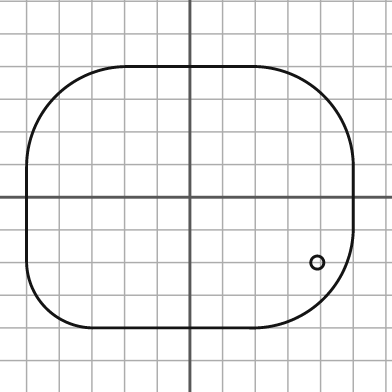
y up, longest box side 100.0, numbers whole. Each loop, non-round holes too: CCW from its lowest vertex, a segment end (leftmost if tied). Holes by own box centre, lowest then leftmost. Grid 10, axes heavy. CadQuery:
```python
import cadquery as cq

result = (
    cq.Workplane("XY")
    .moveTo(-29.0, -40.0)
    .lineTo(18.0, -40.0)
    .threePointArc((41.0, -31.0), (50.0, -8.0))
    .lineTo(50.0, 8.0)
    .threePointArc((41.0, 31.0), (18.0, 40.0))
    .lineTo(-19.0, 40.0)
    .threePointArc((-41.0, 31.0), (-50.0, 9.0))
    .lineTo(-50.0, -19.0)
    .threePointArc((-44.0, -34.0), (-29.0, -40.0))
    .close()
    .moveTo(39.0, -20.0)
    .circle(2.0)
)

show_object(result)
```